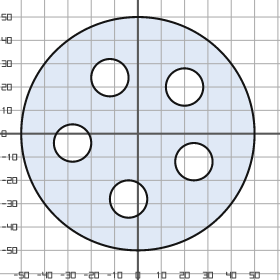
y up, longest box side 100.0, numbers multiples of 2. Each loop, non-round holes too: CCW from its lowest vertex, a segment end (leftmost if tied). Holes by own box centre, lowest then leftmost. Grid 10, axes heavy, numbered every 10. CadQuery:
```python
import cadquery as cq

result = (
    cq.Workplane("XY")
    .moveTo(0.0, 0.0)
    .circle(50.0)
    .moveTo(-4.0, -28.0)
    .circle(8.0)
    .moveTo(24.0, -12.0)
    .circle(8.0)
    .moveTo(-28.0, -4.0)
    .circle(8.0)
    .moveTo(20.0, 20.0)
    .circle(8.0)
    .moveTo(-12.0, 24.0)
    .circle(8.0)
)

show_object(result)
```